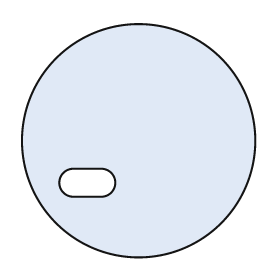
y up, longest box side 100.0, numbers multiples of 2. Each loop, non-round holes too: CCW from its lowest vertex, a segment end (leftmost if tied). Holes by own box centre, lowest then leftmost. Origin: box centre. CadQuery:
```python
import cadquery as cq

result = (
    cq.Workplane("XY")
    .moveTo(0.0, 0.0)
    .circle(50.0)
    .moveTo(-28.0, -24.0)
    .lineTo(-16.0, -24.0)
    .threePointArc((-10.0, -18.0), (-16.0, -12.0))
    .lineTo(-28.0, -12.0)
    .threePointArc((-34.0, -18.0), (-28.0, -24.0))
    .close()
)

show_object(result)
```